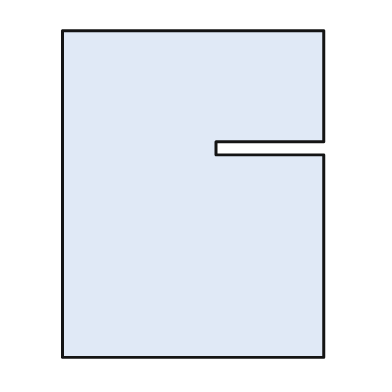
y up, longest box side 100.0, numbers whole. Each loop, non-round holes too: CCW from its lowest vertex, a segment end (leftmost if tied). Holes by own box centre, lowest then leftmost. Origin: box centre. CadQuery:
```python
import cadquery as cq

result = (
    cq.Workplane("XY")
    .moveTo(-40.0, -50.0)
    .lineTo(40.0, -50.0)
    .lineTo(40.0, 12.0)
    .lineTo(7.0, 12.0)
    .lineTo(7.0, 16.0)
    .lineTo(40.0, 16.0)
    .lineTo(40.0, 50.0)
    .lineTo(-40.0, 50.0)
    .close()
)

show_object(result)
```